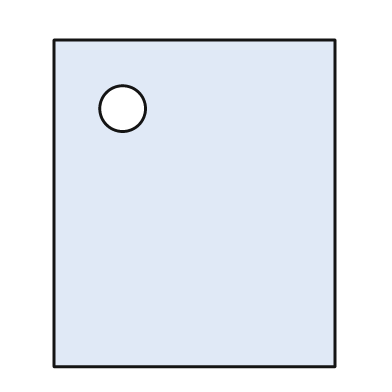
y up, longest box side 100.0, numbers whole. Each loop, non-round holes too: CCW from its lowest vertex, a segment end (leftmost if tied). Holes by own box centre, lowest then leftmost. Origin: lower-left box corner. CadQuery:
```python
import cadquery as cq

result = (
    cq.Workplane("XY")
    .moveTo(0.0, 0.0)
    .lineTo(86.0, 0.0)
    .lineTo(86.0, 100.0)
    .lineTo(0.0, 100.0)
    .close()
    .moveTo(21.0, 79.0)
    .circle(7.0)
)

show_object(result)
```